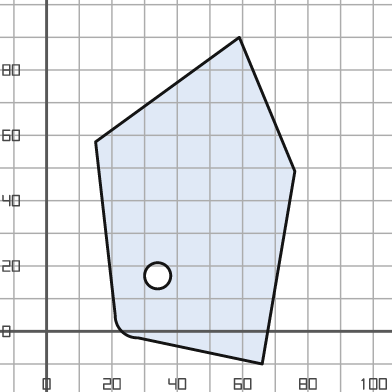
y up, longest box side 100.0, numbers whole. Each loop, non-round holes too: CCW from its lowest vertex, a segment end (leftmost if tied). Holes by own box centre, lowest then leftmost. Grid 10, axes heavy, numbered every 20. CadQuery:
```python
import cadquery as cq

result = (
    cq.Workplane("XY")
    .moveTo(66.0, -10.0)
    .lineTo(76.0, 49.0)
    .lineTo(59.0, 90.0)
    .lineTo(15.0, 58.0)
    .lineTo(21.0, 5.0)
    .threePointArc((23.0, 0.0), (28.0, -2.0))
    .close()
    .moveTo(34.0, 17.0)
    .circle(4.0)
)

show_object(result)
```